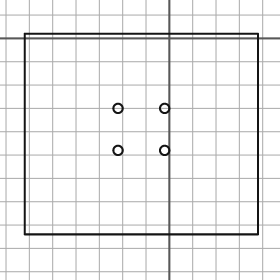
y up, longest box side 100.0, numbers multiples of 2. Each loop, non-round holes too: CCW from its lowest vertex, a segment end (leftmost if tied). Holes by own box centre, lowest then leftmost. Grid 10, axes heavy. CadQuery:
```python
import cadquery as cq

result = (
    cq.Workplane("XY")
    .moveTo(-62.0, -84.0)
    .lineTo(38.0, -84.0)
    .lineTo(38.0, 2.0)
    .lineTo(-62.0, 2.0)
    .close()
    .moveTo(-22.0, -48.0)
    .circle(2.0)
    .moveTo(-2.0, -48.0)
    .circle(2.0)
    .moveTo(-22.0, -30.0)
    .circle(2.0)
    .moveTo(-2.0, -30.0)
    .circle(2.0)
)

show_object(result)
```